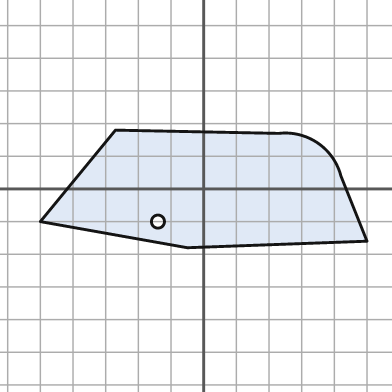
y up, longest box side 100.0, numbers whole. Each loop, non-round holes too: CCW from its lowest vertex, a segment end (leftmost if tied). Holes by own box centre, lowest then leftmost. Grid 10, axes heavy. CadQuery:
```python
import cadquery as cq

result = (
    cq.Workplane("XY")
    .moveTo(-5.0, -18.0)
    .lineTo(50.0, -16.0)
    .lineTo(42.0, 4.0)
    .threePointArc((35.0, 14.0), (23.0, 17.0))
    .lineTo(-27.0, 18.0)
    .lineTo(-50.0, -10.0)
    .close()
    .moveTo(-14.0, -10.0)
    .circle(2.0)
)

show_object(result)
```